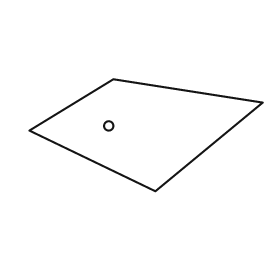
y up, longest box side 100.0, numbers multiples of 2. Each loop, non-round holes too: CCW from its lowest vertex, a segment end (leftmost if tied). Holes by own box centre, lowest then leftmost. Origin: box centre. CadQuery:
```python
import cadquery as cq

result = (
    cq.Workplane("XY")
    .moveTo(4.0, -24.0)
    .lineTo(50.0, 14.0)
    .lineTo(-14.0, 24.0)
    .lineTo(-50.0, 2.0)
    .close()
    .moveTo(-16.0, 4.0)
    .circle(2.0)
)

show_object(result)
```